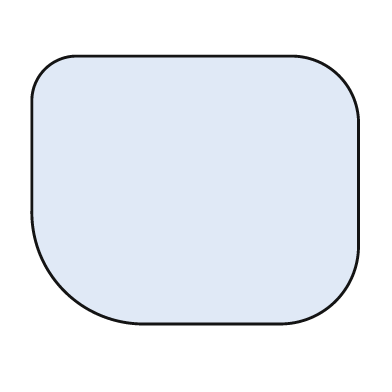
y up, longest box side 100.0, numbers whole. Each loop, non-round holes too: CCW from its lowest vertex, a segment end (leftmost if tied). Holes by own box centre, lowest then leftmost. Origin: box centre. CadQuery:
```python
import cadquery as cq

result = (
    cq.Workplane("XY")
    .moveTo(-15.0, -41.0)
    .lineTo(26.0, -41.0)
    .threePointArc((43.0, -34.0), (50.0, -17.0))
    .lineTo(50.0, 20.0)
    .threePointArc((44.0, 35.0), (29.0, 41.0))
    .lineTo(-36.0, 41.0)
    .threePointArc((-46.0, 37.0), (-50.0, 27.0))
    .lineTo(-50.0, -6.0)
    .threePointArc((-40.0, -31.0), (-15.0, -41.0))
    .close()
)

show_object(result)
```